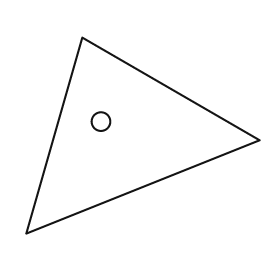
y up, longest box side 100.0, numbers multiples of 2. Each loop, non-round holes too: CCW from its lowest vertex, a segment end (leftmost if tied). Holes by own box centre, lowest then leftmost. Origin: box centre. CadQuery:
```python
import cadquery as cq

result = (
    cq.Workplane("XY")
    .moveTo(-50.0, -42.0)
    .lineTo(50.0, -2.0)
    .lineTo(-26.0, 42.0)
    .close()
    .moveTo(-18.0, 6.0)
    .circle(4.0)
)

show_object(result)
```